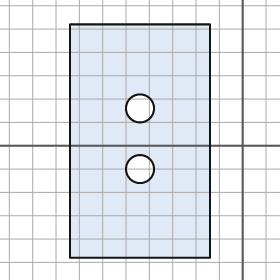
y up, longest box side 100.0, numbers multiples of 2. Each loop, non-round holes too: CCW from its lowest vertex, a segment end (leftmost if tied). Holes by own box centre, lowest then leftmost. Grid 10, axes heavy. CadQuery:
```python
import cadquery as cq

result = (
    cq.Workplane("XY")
    .moveTo(-74.0, -48.0)
    .lineTo(-14.0, -48.0)
    .lineTo(-14.0, 52.0)
    .lineTo(-74.0, 52.0)
    .close()
    .moveTo(-44.0, -10.0)
    .circle(6.0)
    .moveTo(-44.0, 16.0)
    .circle(6.0)
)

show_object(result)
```